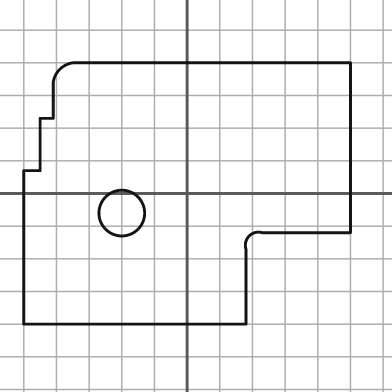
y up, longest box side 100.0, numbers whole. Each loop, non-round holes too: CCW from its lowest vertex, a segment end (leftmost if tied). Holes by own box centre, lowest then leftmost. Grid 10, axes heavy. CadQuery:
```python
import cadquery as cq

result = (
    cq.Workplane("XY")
    .moveTo(-50.0, -40.0)
    .lineTo(18.0, -40.0)
    .lineTo(18.0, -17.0)
    .threePointArc((19.0, -13.0), (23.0, -12.0))
    .lineTo(50.0, -12.0)
    .lineTo(50.0, 40.0)
    .lineTo(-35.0, 40.0)
    .threePointArc((-39.0, 38.0), (-41.0, 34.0))
    .lineTo(-41.0, 23.0)
    .lineTo(-45.0, 23.0)
    .lineTo(-45.0, 7.0)
    .lineTo(-50.0, 7.0)
    .close()
    .moveTo(-20.0, -6.0)
    .circle(7.0)
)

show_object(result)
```